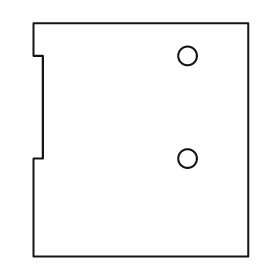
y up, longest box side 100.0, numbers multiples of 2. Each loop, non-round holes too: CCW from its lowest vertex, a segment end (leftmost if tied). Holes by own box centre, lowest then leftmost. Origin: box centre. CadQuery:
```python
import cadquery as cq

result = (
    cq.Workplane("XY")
    .moveTo(-46.0, -50.0)
    .lineTo(46.0, -50.0)
    .lineTo(46.0, 50.0)
    .lineTo(-46.0, 50.0)
    .lineTo(-46.0, 36.0)
    .lineTo(-42.0, 36.0)
    .lineTo(-42.0, -8.0)
    .lineTo(-46.0, -8.0)
    .close()
    .moveTo(20.0, -8.0)
    .circle(4.0)
    .moveTo(20.0, 36.0)
    .circle(4.0)
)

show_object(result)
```